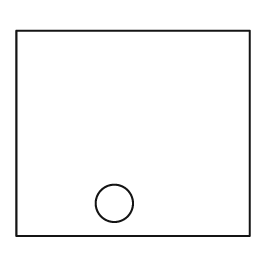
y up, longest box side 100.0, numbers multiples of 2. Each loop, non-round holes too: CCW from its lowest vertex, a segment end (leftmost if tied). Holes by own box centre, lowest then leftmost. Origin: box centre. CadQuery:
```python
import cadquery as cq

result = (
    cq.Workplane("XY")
    .moveTo(-50.0, -44.0)
    .lineTo(50.0, -44.0)
    .lineTo(50.0, 44.0)
    .lineTo(-50.0, 44.0)
    .close()
    .moveTo(-8.0, -30.0)
    .circle(8.0)
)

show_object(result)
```